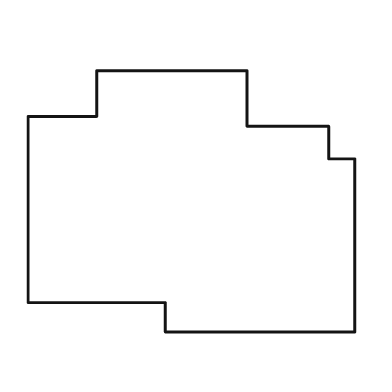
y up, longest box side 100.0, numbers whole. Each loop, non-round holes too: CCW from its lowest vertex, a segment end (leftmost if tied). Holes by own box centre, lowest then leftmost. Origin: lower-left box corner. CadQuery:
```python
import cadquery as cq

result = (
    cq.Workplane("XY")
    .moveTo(42.0, 0.0)
    .lineTo(100.0, 0.0)
    .lineTo(100.0, 53.0)
    .lineTo(92.0, 53.0)
    .lineTo(92.0, 63.0)
    .lineTo(67.0, 63.0)
    .lineTo(67.0, 80.0)
    .lineTo(21.0, 80.0)
    .lineTo(21.0, 66.0)
    .lineTo(0.0, 66.0)
    .lineTo(0.0, 9.0)
    .lineTo(42.0, 9.0)
    .close()
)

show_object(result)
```